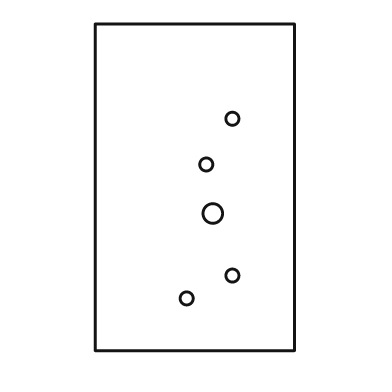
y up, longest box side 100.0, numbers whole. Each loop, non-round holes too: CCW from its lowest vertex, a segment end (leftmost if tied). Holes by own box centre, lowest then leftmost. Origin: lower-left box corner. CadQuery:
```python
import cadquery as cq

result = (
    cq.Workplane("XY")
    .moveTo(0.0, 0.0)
    .lineTo(61.0, 0.0)
    .lineTo(61.0, 100.0)
    .lineTo(0.0, 100.0)
    .close()
    .moveTo(28.0, 16.0)
    .circle(2.0)
    .moveTo(42.0, 23.0)
    .circle(2.0)
    .moveTo(36.0, 42.0)
    .circle(3.0)
    .moveTo(34.0, 57.0)
    .circle(2.0)
    .moveTo(42.0, 71.0)
    .circle(2.0)
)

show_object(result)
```